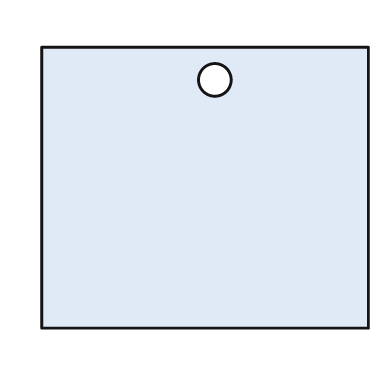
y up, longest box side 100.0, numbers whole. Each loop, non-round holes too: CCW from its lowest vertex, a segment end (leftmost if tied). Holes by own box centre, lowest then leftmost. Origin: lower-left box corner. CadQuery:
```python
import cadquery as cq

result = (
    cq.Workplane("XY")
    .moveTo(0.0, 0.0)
    .lineTo(100.0, 0.0)
    .lineTo(100.0, 86.0)
    .lineTo(0.0, 86.0)
    .close()
    .moveTo(53.0, 76.0)
    .circle(5.0)
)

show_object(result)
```